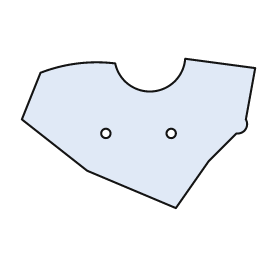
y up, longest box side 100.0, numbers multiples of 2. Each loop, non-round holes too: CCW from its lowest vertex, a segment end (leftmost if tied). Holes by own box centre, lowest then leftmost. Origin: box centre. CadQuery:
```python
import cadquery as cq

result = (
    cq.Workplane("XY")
    .moveTo(16.0, -32.0)
    .lineTo(30.0, -12.0)
    .lineTo(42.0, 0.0)
    .threePointArc((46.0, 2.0), (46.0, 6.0))
    .lineTo(50.0, 28.0)
    .lineTo(20.0, 32.0)
    .threePointArc((6.0, 18.0), (-10.0, 30.0))
    .threePointArc((-26.0, 30.0), (-42.0, 26.0))
    .lineTo(-50.0, 6.0)
    .lineTo(-22.0, -16.0)
    .close()
    .moveTo(-14.0, 0.0)
    .circle(2.0)
    .moveTo(14.0, 0.0)
    .circle(2.0)
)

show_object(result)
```